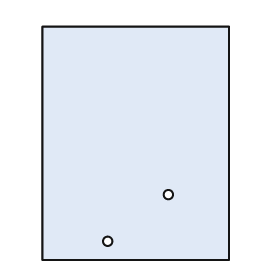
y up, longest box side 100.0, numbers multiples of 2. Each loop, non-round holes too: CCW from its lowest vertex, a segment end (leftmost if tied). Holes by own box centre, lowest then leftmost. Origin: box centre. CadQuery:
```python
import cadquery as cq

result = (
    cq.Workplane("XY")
    .moveTo(-40.0, -50.0)
    .lineTo(40.0, -50.0)
    .lineTo(40.0, 50.0)
    .lineTo(-40.0, 50.0)
    .close()
    .moveTo(-12.0, -42.0)
    .circle(2.0)
    .moveTo(14.0, -22.0)
    .circle(2.0)
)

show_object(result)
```